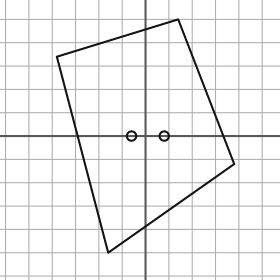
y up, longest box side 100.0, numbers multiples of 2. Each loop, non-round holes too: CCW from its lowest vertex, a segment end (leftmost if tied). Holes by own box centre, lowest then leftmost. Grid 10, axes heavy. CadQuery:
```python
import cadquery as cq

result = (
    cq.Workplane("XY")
    .moveTo(-16.0, -50.0)
    .lineTo(38.0, -12.0)
    .lineTo(14.0, 50.0)
    .lineTo(-38.0, 34.0)
    .close()
    .moveTo(-6.0, 0.0)
    .circle(2.0)
    .moveTo(8.0, 0.0)
    .circle(2.0)
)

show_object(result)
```